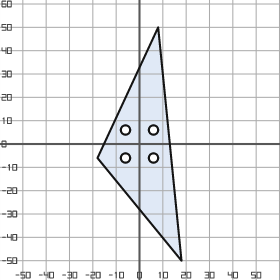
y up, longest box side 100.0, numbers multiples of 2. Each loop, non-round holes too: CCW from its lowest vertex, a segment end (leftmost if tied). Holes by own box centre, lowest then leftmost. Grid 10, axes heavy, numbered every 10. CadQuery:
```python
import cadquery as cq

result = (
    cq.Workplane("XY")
    .moveTo(18.0, -50.0)
    .lineTo(8.0, 50.0)
    .lineTo(-18.0, -6.0)
    .close()
    .moveTo(-6.0, -6.0)
    .circle(2.0)
    .moveTo(6.0, -6.0)
    .circle(2.0)
    .moveTo(-6.0, 6.0)
    .circle(2.0)
    .moveTo(6.0, 6.0)
    .circle(2.0)
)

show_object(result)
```